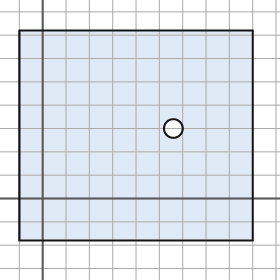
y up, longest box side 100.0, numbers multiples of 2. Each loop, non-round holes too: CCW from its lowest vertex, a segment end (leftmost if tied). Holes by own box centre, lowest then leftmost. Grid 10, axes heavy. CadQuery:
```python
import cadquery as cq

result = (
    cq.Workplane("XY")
    .moveTo(-10.0, -18.0)
    .lineTo(90.0, -18.0)
    .lineTo(90.0, 72.0)
    .lineTo(-10.0, 72.0)
    .close()
    .moveTo(56.0, 30.0)
    .circle(4.0)
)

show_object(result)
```